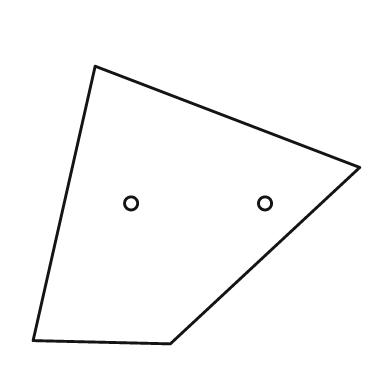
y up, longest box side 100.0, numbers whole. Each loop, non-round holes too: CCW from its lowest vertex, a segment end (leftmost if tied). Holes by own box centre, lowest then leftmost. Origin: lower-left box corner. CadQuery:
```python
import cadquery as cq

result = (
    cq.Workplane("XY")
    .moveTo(42.0, 0.0)
    .lineTo(100.0, 54.0)
    .lineTo(19.0, 85.0)
    .lineTo(0.0, 1.0)
    .close()
    .moveTo(30.0, 43.0)
    .circle(2.0)
    .moveTo(71.0, 43.0)
    .circle(2.0)
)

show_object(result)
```